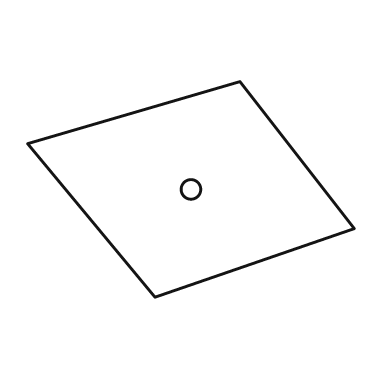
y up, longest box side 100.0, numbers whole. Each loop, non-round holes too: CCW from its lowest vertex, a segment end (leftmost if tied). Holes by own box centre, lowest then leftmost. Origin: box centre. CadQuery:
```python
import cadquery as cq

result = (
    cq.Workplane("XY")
    .moveTo(-11.0, -33.0)
    .lineTo(50.0, -12.0)
    .lineTo(15.0, 33.0)
    .lineTo(-50.0, 14.0)
    .close()
    .moveTo(0.0, 0.0)
    .circle(3.0)
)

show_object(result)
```